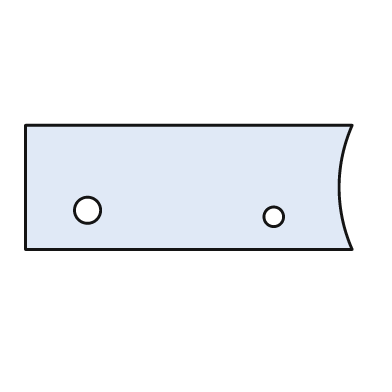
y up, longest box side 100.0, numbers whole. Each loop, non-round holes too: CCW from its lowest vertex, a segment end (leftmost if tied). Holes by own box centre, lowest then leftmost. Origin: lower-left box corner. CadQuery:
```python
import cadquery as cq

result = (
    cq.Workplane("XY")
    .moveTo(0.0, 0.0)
    .lineTo(100.0, 0.0)
    .threePointArc((96.0, 19.0), (100.0, 38.0))
    .lineTo(0.0, 38.0)
    .close()
    .moveTo(76.0, 10.0)
    .circle(3.0)
    .moveTo(19.0, 12.0)
    .circle(4.0)
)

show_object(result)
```